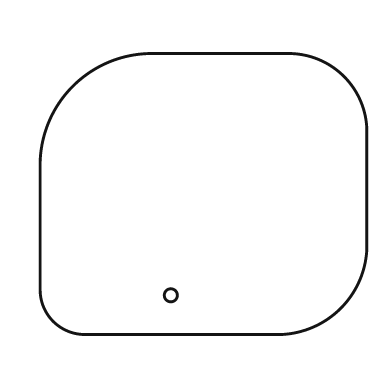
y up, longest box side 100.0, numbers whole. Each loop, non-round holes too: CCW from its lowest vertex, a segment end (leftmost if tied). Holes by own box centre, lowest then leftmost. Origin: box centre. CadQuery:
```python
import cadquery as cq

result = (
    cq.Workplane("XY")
    .moveTo(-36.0, -43.0)
    .lineTo(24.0, -43.0)
    .threePointArc((42.0, -35.0), (50.0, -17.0))
    .lineTo(50.0, 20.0)
    .threePointArc((43.0, 36.0), (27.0, 43.0))
    .lineTo(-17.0, 43.0)
    .threePointArc((-40.0, 33.0), (-50.0, 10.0))
    .lineTo(-50.0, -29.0)
    .threePointArc((-46.0, -39.0), (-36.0, -43.0))
    .close()
    .moveTo(-10.0, -31.0)
    .circle(2.0)
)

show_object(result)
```